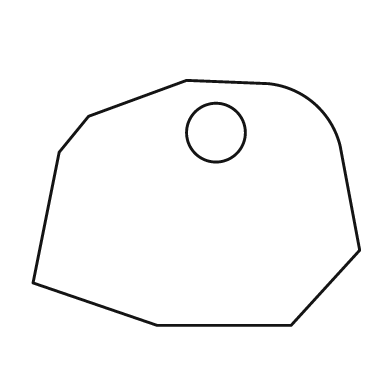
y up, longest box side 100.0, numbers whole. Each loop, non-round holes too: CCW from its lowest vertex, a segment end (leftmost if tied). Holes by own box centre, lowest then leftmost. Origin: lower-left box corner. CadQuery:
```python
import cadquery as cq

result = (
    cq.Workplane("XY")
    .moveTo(38.0, 0.0)
    .lineTo(79.0, 0.0)
    .lineTo(100.0, 23.0)
    .lineTo(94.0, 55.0)
    .threePointArc((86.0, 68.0), (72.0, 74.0))
    .lineTo(47.0, 75.0)
    .lineTo(17.0, 64.0)
    .lineTo(8.0, 53.0)
    .lineTo(0.0, 13.0)
    .close()
    .moveTo(56.0, 59.0)
    .circle(9.0)
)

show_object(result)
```